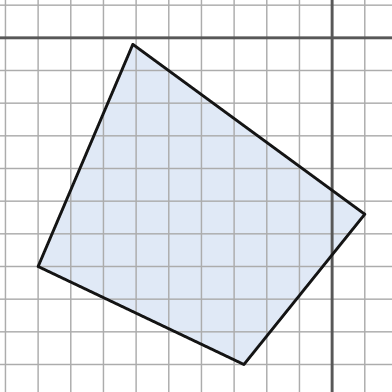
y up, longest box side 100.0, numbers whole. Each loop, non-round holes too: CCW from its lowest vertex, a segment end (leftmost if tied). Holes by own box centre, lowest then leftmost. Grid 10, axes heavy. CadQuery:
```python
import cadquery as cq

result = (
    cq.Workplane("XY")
    .moveTo(-27.0, -100.0)
    .lineTo(10.0, -54.0)
    .lineTo(-61.0, -2.0)
    .lineTo(-90.0, -70.0)
    .close()
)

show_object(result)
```